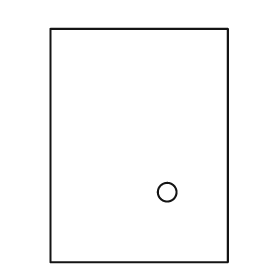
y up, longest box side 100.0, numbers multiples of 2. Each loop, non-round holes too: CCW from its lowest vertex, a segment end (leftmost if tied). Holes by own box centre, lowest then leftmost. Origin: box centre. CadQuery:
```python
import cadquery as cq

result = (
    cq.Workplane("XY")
    .moveTo(-38.0, -50.0)
    .lineTo(38.0, -50.0)
    .lineTo(38.0, 50.0)
    .lineTo(-38.0, 50.0)
    .close()
    .moveTo(12.0, -20.0)
    .circle(4.0)
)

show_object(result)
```